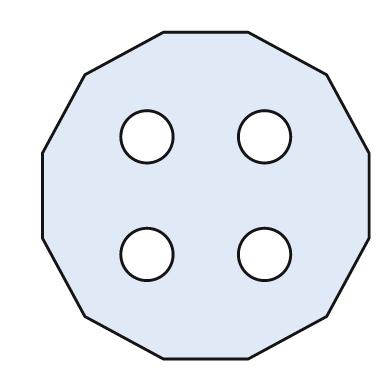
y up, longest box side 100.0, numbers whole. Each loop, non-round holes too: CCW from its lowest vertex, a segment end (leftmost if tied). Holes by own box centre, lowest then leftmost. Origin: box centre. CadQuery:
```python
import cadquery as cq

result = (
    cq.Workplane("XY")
    .moveTo(-13.0, -50.0)
    .lineTo(13.0, -50.0)
    .lineTo(37.0, -37.0)
    .lineTo(50.0, -13.0)
    .lineTo(50.0, 13.0)
    .lineTo(37.0, 37.0)
    .lineTo(13.0, 50.0)
    .lineTo(-13.0, 50.0)
    .lineTo(-37.0, 37.0)
    .lineTo(-50.0, 13.0)
    .lineTo(-50.0, -13.0)
    .lineTo(-37.0, -37.0)
    .close()
    .moveTo(-18.0, -18.0)
    .circle(8.0)
    .moveTo(18.0, -18.0)
    .circle(8.0)
    .moveTo(-18.0, 18.0)
    .circle(8.0)
    .moveTo(18.0, 18.0)
    .circle(8.0)
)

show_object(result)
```